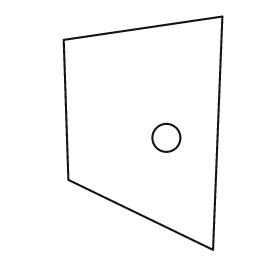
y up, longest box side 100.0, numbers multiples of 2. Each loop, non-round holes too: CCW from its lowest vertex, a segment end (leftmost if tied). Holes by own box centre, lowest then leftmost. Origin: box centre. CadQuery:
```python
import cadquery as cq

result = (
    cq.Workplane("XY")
    .moveTo(30.0, -50.0)
    .lineTo(34.0, 50.0)
    .lineTo(-34.0, 40.0)
    .lineTo(-32.0, -20.0)
    .close()
    .moveTo(10.0, -2.0)
    .circle(6.0)
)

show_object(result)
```